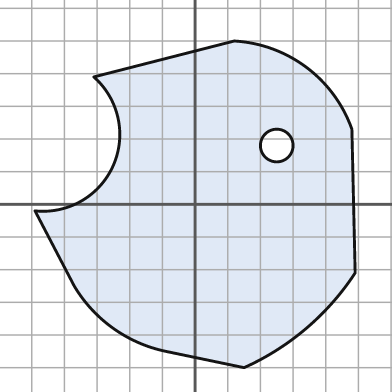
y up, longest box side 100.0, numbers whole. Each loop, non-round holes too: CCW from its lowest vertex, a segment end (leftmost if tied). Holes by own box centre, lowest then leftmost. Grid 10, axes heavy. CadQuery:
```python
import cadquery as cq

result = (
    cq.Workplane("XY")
    .moveTo(15.0, -50.0)
    .threePointArc((34.0, -38.0), (49.0, -21.0))
    .lineTo(48.0, 23.0)
    .threePointArc((34.0, 42.0), (12.0, 50.0))
    .lineTo(-31.0, 39.0)
    .threePointArc((-25.0, 12.0), (-49.0, -2.0))
    .lineTo(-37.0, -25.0)
    .threePointArc((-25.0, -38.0), (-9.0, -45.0))
    .close()
    .moveTo(25.0, 18.0)
    .circle(5.0)
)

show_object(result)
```